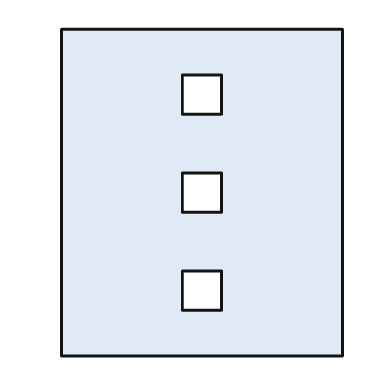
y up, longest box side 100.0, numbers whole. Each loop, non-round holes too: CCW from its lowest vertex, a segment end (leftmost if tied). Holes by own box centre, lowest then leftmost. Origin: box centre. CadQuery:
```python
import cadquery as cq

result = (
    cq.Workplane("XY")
    .moveTo(-43.0, -50.0)
    .lineTo(43.0, -50.0)
    .lineTo(43.0, 50.0)
    .lineTo(-43.0, 50.0)
    .close()
    .moveTo(-6.0, -36.0)
    .lineTo(6.0, -36.0)
    .lineTo(6.0, -24.0)
    .lineTo(-6.0, -24.0)
    .close()
    .moveTo(-6.0, -6.0)
    .lineTo(6.0, -6.0)
    .lineTo(6.0, 6.0)
    .lineTo(-6.0, 6.0)
    .close()
    .moveTo(-6.0, 24.0)
    .lineTo(6.0, 24.0)
    .lineTo(6.0, 36.0)
    .lineTo(-6.0, 36.0)
    .close()
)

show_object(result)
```